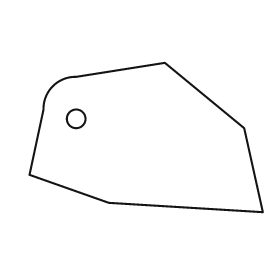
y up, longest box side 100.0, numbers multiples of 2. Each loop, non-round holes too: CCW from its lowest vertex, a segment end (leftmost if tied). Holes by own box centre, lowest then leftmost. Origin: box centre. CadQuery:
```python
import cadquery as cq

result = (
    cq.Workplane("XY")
    .moveTo(50.0, -32.0)
    .lineTo(42.0, 4.0)
    .lineTo(8.0, 32.0)
    .lineTo(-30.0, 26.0)
    .threePointArc((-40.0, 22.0), (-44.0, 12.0))
    .lineTo(-50.0, -16.0)
    .lineTo(-16.0, -28.0)
    .close()
    .moveTo(-30.0, 8.0)
    .circle(4.0)
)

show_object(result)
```